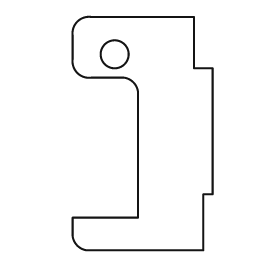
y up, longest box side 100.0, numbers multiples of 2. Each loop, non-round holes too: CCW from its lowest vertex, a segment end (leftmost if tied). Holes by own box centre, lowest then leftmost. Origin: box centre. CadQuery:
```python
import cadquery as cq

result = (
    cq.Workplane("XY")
    .moveTo(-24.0, -50.0)
    .lineTo(26.0, -50.0)
    .lineTo(26.0, -26.0)
    .lineTo(30.0, -26.0)
    .lineTo(30.0, 28.0)
    .lineTo(22.0, 28.0)
    .lineTo(22.0, 50.0)
    .lineTo(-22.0, 50.0)
    .threePointArc((-28.0, 48.0), (-30.0, 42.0))
    .lineTo(-30.0, 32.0)
    .threePointArc((-28.0, 26.0), (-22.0, 24.0))
    .lineTo(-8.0, 24.0)
    .threePointArc((-4.0, 22.0), (-2.0, 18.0))
    .lineTo(-2.0, -36.0)
    .lineTo(-30.0, -36.0)
    .lineTo(-30.0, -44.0)
    .threePointArc((-28.0, -48.0), (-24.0, -50.0))
    .close()
    .moveTo(-12.0, 34.0)
    .circle(6.0)
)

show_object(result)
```